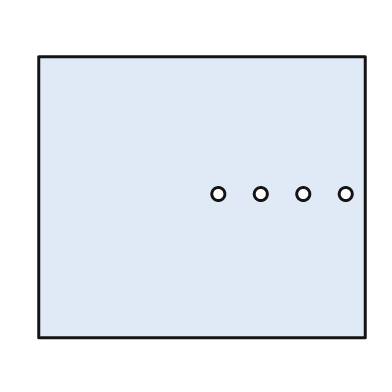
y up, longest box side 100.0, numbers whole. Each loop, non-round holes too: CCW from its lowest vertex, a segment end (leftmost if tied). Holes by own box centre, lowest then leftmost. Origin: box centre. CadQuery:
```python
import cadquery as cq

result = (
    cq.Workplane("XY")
    .moveTo(-50.0, -43.0)
    .lineTo(50.0, -43.0)
    .lineTo(50.0, 43.0)
    .lineTo(-50.0, 43.0)
    .close()
    .moveTo(5.0, 1.0)
    .circle(2.0)
    .moveTo(18.0, 1.0)
    .circle(2.0)
    .moveTo(31.0, 1.0)
    .circle(2.0)
    .moveTo(44.0, 1.0)
    .circle(2.0)
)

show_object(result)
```